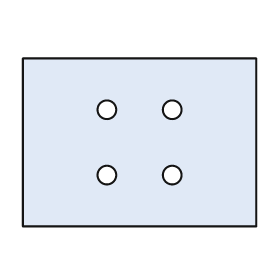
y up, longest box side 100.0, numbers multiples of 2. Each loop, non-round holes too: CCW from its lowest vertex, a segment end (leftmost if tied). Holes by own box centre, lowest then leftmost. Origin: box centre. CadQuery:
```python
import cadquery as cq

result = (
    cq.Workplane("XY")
    .moveTo(-50.0, -36.0)
    .lineTo(50.0, -36.0)
    .lineTo(50.0, 36.0)
    .lineTo(-50.0, 36.0)
    .close()
    .moveTo(-14.0, -14.0)
    .circle(4.0)
    .moveTo(14.0, -14.0)
    .circle(4.0)
    .moveTo(-14.0, 14.0)
    .circle(4.0)
    .moveTo(14.0, 14.0)
    .circle(4.0)
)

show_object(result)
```